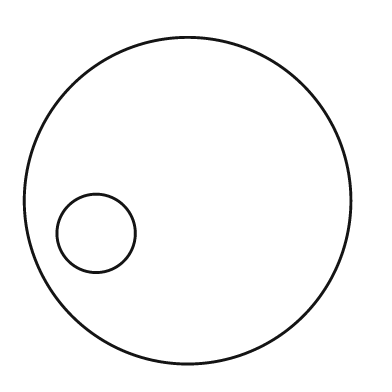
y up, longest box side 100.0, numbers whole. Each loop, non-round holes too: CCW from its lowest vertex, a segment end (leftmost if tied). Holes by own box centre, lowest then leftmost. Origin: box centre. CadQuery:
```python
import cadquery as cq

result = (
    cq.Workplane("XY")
    .moveTo(0.0, 0.0)
    .circle(50.0)
    .moveTo(-28.0, -10.0)
    .circle(12.0)
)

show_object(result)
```